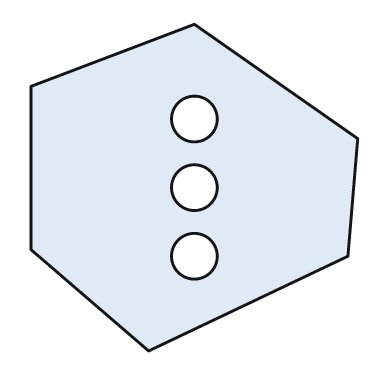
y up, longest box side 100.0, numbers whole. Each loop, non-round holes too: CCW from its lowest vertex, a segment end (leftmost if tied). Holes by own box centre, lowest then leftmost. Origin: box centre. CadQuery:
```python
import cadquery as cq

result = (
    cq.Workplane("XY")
    .moveTo(-14.0, -50.0)
    .lineTo(47.0, -21.0)
    .lineTo(50.0, 15.0)
    .lineTo(0.0, 50.0)
    .lineTo(-50.0, 31.0)
    .lineTo(-50.0, -19.0)
    .close()
    .moveTo(0.0, -21.0)
    .circle(7.0)
    .moveTo(0.0, 0.0)
    .circle(7.0)
    .moveTo(0.0, 21.0)
    .circle(7.0)
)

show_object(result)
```